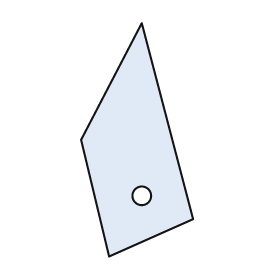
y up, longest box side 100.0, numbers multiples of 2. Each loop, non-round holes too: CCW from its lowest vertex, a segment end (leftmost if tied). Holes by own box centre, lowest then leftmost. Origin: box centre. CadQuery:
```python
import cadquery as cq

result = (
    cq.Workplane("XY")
    .moveTo(-12.0, -50.0)
    .lineTo(24.0, -34.0)
    .lineTo(2.0, 50.0)
    .lineTo(-24.0, 0.0)
    .close()
    .moveTo(2.0, -24.0)
    .circle(4.0)
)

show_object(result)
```